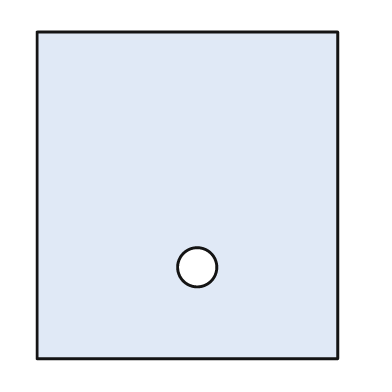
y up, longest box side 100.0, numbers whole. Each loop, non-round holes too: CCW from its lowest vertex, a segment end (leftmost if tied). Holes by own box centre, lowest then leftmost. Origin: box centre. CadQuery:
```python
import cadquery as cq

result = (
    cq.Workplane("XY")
    .moveTo(-46.0, -50.0)
    .lineTo(46.0, -50.0)
    .lineTo(46.0, 50.0)
    .lineTo(-46.0, 50.0)
    .close()
    .moveTo(3.0, -22.0)
    .circle(6.0)
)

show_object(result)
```